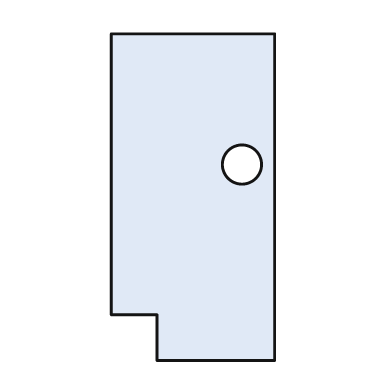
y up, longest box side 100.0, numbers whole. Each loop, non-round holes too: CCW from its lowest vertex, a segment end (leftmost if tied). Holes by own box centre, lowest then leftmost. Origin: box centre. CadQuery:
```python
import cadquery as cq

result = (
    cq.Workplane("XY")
    .moveTo(-11.0, -50.0)
    .lineTo(25.0, -50.0)
    .lineTo(25.0, 50.0)
    .lineTo(-25.0, 50.0)
    .lineTo(-25.0, -36.0)
    .lineTo(-11.0, -36.0)
    .close()
    .moveTo(15.0, 10.0)
    .circle(6.0)
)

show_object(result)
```